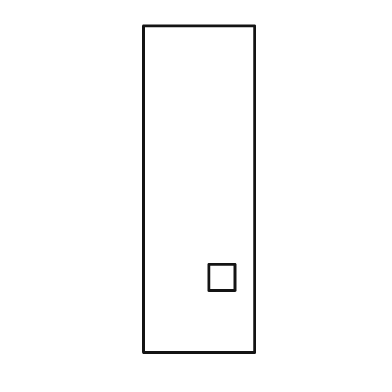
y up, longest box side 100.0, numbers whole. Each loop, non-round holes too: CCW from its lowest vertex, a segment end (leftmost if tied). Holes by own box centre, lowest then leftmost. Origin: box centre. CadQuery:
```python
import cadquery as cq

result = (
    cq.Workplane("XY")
    .moveTo(-17.0, -50.0)
    .lineTo(17.0, -50.0)
    .lineTo(17.0, 50.0)
    .lineTo(-17.0, 50.0)
    .close()
    .moveTo(3.0, -31.0)
    .lineTo(11.0, -31.0)
    .lineTo(11.0, -23.0)
    .lineTo(3.0, -23.0)
    .close()
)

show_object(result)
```